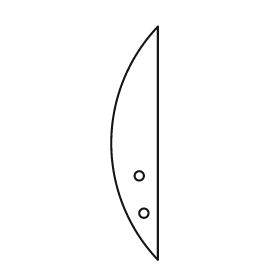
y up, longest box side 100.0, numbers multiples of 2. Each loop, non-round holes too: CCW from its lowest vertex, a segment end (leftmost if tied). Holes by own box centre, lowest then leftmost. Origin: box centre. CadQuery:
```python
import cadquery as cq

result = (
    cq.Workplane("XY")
    .moveTo(10.0, -50.0)
    .lineTo(10.0, 50.0)
    .threePointArc((-10.0, 0.0), (10.0, -50.0))
    .close()
    .moveTo(4.0, -30.0)
    .circle(2.0)
    .moveTo(2.0, -14.0)
    .circle(2.0)
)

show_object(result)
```